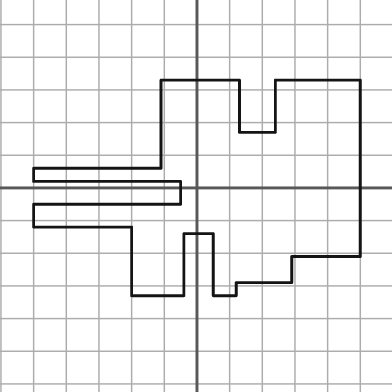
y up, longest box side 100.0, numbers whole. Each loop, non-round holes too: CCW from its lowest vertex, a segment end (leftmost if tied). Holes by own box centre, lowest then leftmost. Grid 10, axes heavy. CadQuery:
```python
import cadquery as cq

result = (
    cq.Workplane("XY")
    .moveTo(-20.0, -33.0)
    .lineTo(-4.0, -33.0)
    .lineTo(-4.0, -14.0)
    .lineTo(5.0, -14.0)
    .lineTo(5.0, -33.0)
    .lineTo(12.0, -33.0)
    .lineTo(12.0, -29.0)
    .lineTo(29.0, -29.0)
    .lineTo(29.0, -21.0)
    .lineTo(50.0, -21.0)
    .lineTo(50.0, 33.0)
    .lineTo(24.0, 33.0)
    .lineTo(24.0, 17.0)
    .lineTo(13.0, 17.0)
    .lineTo(13.0, 33.0)
    .lineTo(-11.0, 33.0)
    .lineTo(-11.0, 6.0)
    .lineTo(-50.0, 6.0)
    .lineTo(-50.0, 2.0)
    .lineTo(-5.0, 2.0)
    .lineTo(-5.0, -5.0)
    .lineTo(-50.0, -5.0)
    .lineTo(-50.0, -12.0)
    .lineTo(-20.0, -12.0)
    .close()
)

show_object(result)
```